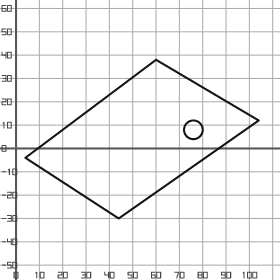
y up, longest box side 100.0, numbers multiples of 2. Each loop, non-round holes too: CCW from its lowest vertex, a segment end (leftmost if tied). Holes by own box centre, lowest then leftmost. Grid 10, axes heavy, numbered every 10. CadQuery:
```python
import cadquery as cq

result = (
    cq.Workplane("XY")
    .moveTo(44.0, -30.0)
    .lineTo(104.0, 12.0)
    .lineTo(60.0, 38.0)
    .lineTo(4.0, -4.0)
    .close()
    .moveTo(76.0, 8.0)
    .circle(4.0)
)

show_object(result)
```